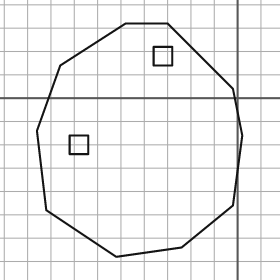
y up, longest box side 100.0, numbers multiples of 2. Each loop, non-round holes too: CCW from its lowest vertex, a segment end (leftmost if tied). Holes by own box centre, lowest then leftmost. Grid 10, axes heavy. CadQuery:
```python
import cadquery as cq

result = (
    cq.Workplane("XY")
    .moveTo(-52.0, -68.0)
    .lineTo(-24.0, -64.0)
    .lineTo(-2.0, -46.0)
    .lineTo(2.0, -16.0)
    .lineTo(-2.0, 4.0)
    .lineTo(-30.0, 32.0)
    .lineTo(-48.0, 32.0)
    .lineTo(-76.0, 14.0)
    .lineTo(-86.0, -14.0)
    .lineTo(-82.0, -48.0)
    .close()
    .moveTo(-72.0, -24.0)
    .lineTo(-64.0, -24.0)
    .lineTo(-64.0, -16.0)
    .lineTo(-72.0, -16.0)
    .close()
    .moveTo(-36.0, 14.0)
    .lineTo(-28.0, 14.0)
    .lineTo(-28.0, 22.0)
    .lineTo(-36.0, 22.0)
    .close()
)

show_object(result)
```